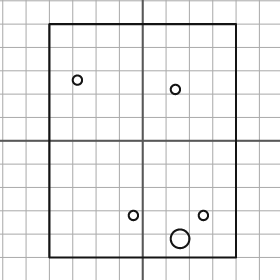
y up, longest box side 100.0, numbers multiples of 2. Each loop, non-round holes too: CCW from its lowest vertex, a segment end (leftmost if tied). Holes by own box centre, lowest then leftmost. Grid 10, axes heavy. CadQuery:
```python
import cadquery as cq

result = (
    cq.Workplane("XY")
    .moveTo(-40.0, -50.0)
    .lineTo(40.0, -50.0)
    .lineTo(40.0, 50.0)
    .lineTo(-40.0, 50.0)
    .close()
    .moveTo(16.0, -42.0)
    .circle(4.0)
    .moveTo(-4.0, -32.0)
    .circle(2.0)
    .moveTo(26.0, -32.0)
    .circle(2.0)
    .moveTo(14.0, 22.0)
    .circle(2.0)
    .moveTo(-28.0, 26.0)
    .circle(2.0)
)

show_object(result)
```